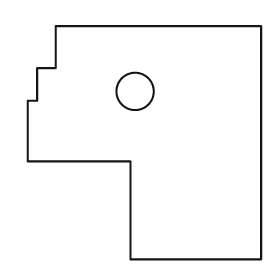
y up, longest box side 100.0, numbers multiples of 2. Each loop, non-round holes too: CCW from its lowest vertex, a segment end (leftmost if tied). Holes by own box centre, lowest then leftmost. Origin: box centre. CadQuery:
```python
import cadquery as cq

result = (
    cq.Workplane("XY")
    .moveTo(-6.0, -50.0)
    .lineTo(50.0, -50.0)
    .lineTo(50.0, 50.0)
    .lineTo(-38.0, 50.0)
    .lineTo(-38.0, 32.0)
    .lineTo(-46.0, 32.0)
    .lineTo(-46.0, 18.0)
    .lineTo(-50.0, 18.0)
    .lineTo(-50.0, -8.0)
    .lineTo(-6.0, -8.0)
    .close()
    .moveTo(-4.0, 22.0)
    .circle(8.0)
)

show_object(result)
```